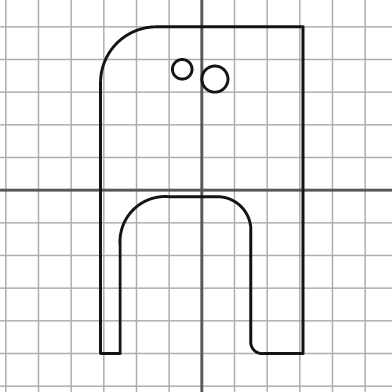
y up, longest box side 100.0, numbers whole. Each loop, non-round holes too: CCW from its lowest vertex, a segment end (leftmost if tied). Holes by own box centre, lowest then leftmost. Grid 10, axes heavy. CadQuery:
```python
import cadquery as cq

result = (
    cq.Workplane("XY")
    .moveTo(-31.0, -50.0)
    .lineTo(-25.0, -50.0)
    .lineTo(-25.0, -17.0)
    .threePointArc((-21.0, -6.0), (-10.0, -2.0))
    .lineTo(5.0, -2.0)
    .threePointArc((12.0, -5.0), (15.0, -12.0))
    .lineTo(15.0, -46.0)
    .threePointArc((16.0, -49.0), (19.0, -50.0))
    .lineTo(31.0, -50.0)
    .lineTo(31.0, 50.0)
    .lineTo(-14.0, 50.0)
    .threePointArc((-26.0, 45.0), (-31.0, 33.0))
    .close()
    .moveTo(4.0, 34.0)
    .circle(4.0)
    .moveTo(-6.0, 37.0)
    .circle(3.0)
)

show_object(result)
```